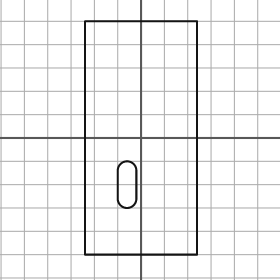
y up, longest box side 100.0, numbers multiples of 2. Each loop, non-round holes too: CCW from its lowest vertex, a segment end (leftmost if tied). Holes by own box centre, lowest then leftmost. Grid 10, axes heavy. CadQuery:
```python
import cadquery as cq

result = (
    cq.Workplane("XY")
    .moveTo(-24.0, -50.0)
    .lineTo(24.0, -50.0)
    .lineTo(24.0, 50.0)
    .lineTo(-24.0, 50.0)
    .close()
    .moveTo(-10.0, -26.0)
    .threePointArc((-6.0, -30.0), (-2.0, -26.0))
    .lineTo(-2.0, -14.0)
    .threePointArc((-6.0, -10.0), (-10.0, -14.0))
    .close()
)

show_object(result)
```